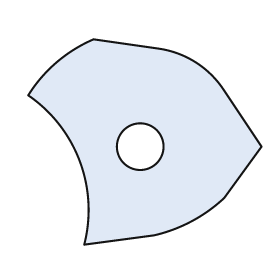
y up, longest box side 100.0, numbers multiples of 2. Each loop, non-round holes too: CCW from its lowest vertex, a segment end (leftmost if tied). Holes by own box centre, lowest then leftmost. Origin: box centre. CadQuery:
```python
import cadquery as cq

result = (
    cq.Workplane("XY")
    .moveTo(-26.0, -44.0)
    .lineTo(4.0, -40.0)
    .threePointArc((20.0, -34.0), (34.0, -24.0))
    .lineTo(50.0, -2.0)
    .lineTo(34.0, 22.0)
    .threePointArc((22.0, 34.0), (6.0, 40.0))
    .lineTo(-22.0, 44.0)
    .threePointArc((-38.0, 34.0), (-50.0, 20.0))
    .threePointArc((-28.0, -8.0), (-26.0, -44.0))
    .close()
    .moveTo(-2.0, -2.0)
    .circle(10.0)
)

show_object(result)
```